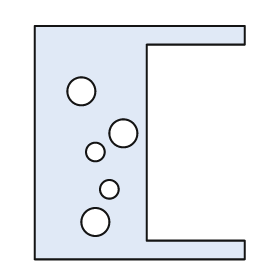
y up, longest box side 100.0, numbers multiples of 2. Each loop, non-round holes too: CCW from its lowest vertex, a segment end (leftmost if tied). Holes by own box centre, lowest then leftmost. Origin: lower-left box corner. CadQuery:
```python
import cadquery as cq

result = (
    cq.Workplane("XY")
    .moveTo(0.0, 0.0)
    .lineTo(90.0, 0.0)
    .lineTo(90.0, 8.0)
    .lineTo(48.0, 8.0)
    .lineTo(48.0, 92.0)
    .lineTo(90.0, 92.0)
    .lineTo(90.0, 100.0)
    .lineTo(0.0, 100.0)
    .close()
    .moveTo(26.0, 16.0)
    .circle(6.0)
    .moveTo(32.0, 30.0)
    .circle(4.0)
    .moveTo(26.0, 46.0)
    .circle(4.0)
    .moveTo(38.0, 54.0)
    .circle(6.0)
    .moveTo(20.0, 72.0)
    .circle(6.0)
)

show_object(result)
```